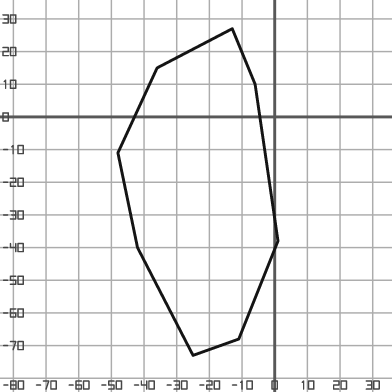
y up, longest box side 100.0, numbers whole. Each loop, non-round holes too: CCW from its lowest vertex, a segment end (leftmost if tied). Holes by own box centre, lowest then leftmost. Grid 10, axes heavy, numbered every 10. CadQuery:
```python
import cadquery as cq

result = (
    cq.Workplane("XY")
    .moveTo(-25.0, -73.0)
    .lineTo(-11.0, -68.0)
    .lineTo(1.0, -38.0)
    .lineTo(-6.0, 10.0)
    .lineTo(-13.0, 27.0)
    .lineTo(-36.0, 15.0)
    .lineTo(-48.0, -11.0)
    .lineTo(-42.0, -40.0)
    .close()
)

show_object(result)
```